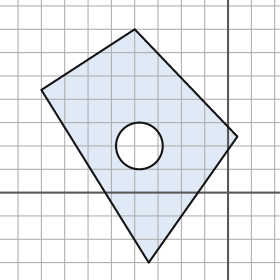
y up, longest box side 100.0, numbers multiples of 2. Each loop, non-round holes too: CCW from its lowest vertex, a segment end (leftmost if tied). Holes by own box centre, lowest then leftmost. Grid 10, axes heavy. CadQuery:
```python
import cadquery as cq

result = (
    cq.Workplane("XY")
    .moveTo(-34.0, -30.0)
    .lineTo(4.0, 24.0)
    .lineTo(-40.0, 70.0)
    .lineTo(-80.0, 44.0)
    .close()
    .moveTo(-38.0, 20.0)
    .circle(10.0)
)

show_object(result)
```